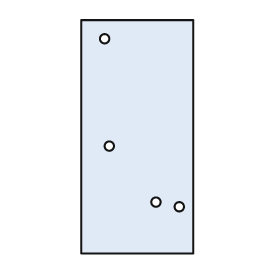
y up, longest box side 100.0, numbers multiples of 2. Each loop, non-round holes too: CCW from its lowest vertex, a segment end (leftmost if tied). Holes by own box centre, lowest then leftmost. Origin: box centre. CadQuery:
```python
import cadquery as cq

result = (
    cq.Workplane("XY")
    .moveTo(-24.0, -50.0)
    .lineTo(24.0, -50.0)
    .lineTo(24.0, 50.0)
    .lineTo(-24.0, 50.0)
    .close()
    .moveTo(18.0, -30.0)
    .circle(2.0)
    .moveTo(8.0, -28.0)
    .circle(2.0)
    .moveTo(-12.0, -4.0)
    .circle(2.0)
    .moveTo(-14.0, 42.0)
    .circle(2.0)
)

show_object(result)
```